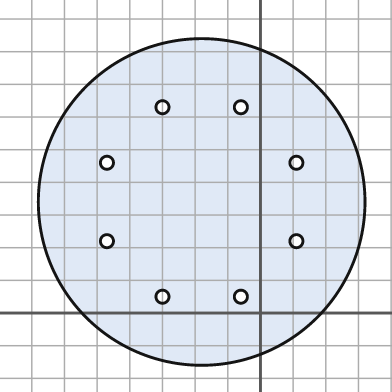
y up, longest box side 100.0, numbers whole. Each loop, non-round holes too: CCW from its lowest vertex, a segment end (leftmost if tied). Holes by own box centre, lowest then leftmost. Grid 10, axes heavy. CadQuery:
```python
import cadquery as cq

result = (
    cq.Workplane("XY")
    .moveTo(-18.0, 34.0)
    .circle(50.0)
    .moveTo(-30.0, 5.0)
    .circle(2.0)
    .moveTo(-6.0, 5.0)
    .circle(2.0)
    .moveTo(-47.0, 22.0)
    .circle(2.0)
    .moveTo(11.0, 22.0)
    .circle(2.0)
    .moveTo(-47.0, 46.0)
    .circle(2.0)
    .moveTo(11.0, 46.0)
    .circle(2.0)
    .moveTo(-30.0, 63.0)
    .circle(2.0)
    .moveTo(-6.0, 63.0)
    .circle(2.0)
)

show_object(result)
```